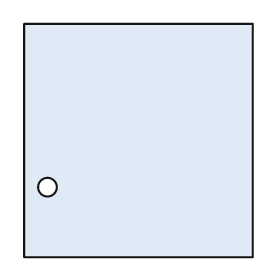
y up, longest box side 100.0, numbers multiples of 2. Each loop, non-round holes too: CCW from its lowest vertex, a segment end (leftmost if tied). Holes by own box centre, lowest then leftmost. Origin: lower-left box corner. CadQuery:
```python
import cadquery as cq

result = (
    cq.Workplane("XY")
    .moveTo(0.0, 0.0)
    .lineTo(98.0, 0.0)
    .lineTo(98.0, 100.0)
    .lineTo(0.0, 100.0)
    .close()
    .moveTo(10.0, 30.0)
    .circle(4.0)
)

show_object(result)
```